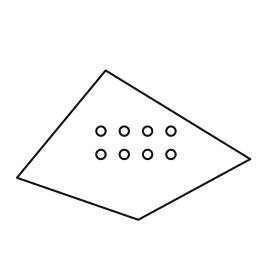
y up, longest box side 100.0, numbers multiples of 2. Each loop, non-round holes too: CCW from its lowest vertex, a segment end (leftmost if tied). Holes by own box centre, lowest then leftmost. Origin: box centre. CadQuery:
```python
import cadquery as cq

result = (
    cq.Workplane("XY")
    .moveTo(2.0, -32.0)
    .lineTo(50.0, -6.0)
    .lineTo(-12.0, 32.0)
    .lineTo(-50.0, -14.0)
    .close()
    .moveTo(-14.0, -4.0)
    .circle(2.0)
    .moveTo(-4.0, -4.0)
    .circle(2.0)
    .moveTo(6.0, -4.0)
    .circle(2.0)
    .moveTo(16.0, -4.0)
    .circle(2.0)
    .moveTo(-14.0, 6.0)
    .circle(2.0)
    .moveTo(-4.0, 6.0)
    .circle(2.0)
    .moveTo(6.0, 6.0)
    .circle(2.0)
    .moveTo(16.0, 6.0)
    .circle(2.0)
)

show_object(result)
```